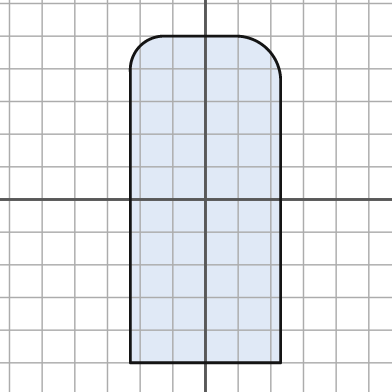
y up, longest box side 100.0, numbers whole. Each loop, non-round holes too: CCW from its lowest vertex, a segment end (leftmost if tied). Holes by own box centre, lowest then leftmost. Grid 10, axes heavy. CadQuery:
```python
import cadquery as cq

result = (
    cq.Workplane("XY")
    .moveTo(-23.0, -50.0)
    .lineTo(23.0, -50.0)
    .lineTo(23.0, 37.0)
    .threePointArc((19.0, 46.0), (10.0, 50.0))
    .lineTo(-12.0, 50.0)
    .threePointArc((-20.0, 47.0), (-23.0, 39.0))
    .close()
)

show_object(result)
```